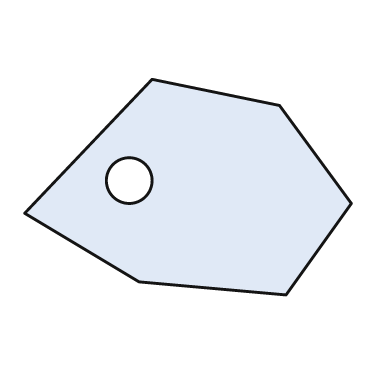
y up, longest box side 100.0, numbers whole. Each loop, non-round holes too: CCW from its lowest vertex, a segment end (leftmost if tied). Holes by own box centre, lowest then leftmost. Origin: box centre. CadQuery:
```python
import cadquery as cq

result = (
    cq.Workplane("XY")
    .moveTo(30.0, -33.0)
    .lineTo(50.0, -5.0)
    .lineTo(28.0, 25.0)
    .lineTo(-11.0, 33.0)
    .lineTo(-50.0, -8.0)
    .lineTo(-15.0, -29.0)
    .close()
    .moveTo(-18.0, 2.0)
    .circle(7.0)
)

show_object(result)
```